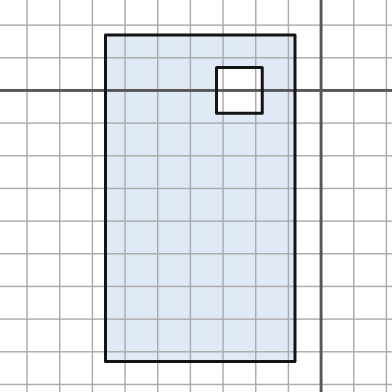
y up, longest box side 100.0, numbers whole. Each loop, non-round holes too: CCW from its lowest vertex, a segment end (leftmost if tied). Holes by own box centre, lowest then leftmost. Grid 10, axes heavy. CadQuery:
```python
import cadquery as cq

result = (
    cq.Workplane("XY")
    .moveTo(-66.0, -83.0)
    .lineTo(-8.0, -83.0)
    .lineTo(-8.0, 17.0)
    .lineTo(-66.0, 17.0)
    .close()
    .moveTo(-32.0, -7.0)
    .lineTo(-18.0, -7.0)
    .lineTo(-18.0, 7.0)
    .lineTo(-32.0, 7.0)
    .close()
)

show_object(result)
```